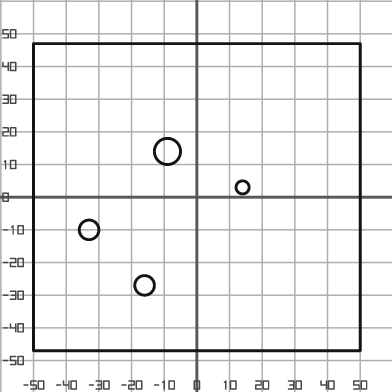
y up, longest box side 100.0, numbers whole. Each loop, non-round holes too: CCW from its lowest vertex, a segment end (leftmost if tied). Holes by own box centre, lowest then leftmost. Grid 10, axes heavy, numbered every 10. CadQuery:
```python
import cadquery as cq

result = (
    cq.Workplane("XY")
    .moveTo(-50.0, -47.0)
    .lineTo(50.0, -47.0)
    .lineTo(50.0, 47.0)
    .lineTo(-50.0, 47.0)
    .close()
    .moveTo(-16.0, -27.0)
    .circle(3.0)
    .moveTo(-33.0, -10.0)
    .circle(3.0)
    .moveTo(14.0, 3.0)
    .circle(2.0)
    .moveTo(-9.0, 14.0)
    .circle(4.0)
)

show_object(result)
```